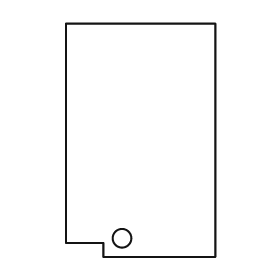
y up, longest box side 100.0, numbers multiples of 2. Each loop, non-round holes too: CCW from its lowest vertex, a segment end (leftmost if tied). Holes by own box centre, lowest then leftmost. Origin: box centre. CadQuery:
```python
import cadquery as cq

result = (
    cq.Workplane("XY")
    .moveTo(-16.0, -50.0)
    .lineTo(32.0, -50.0)
    .lineTo(32.0, 50.0)
    .lineTo(-32.0, 50.0)
    .lineTo(-32.0, -44.0)
    .lineTo(-16.0, -44.0)
    .close()
    .moveTo(-8.0, -42.0)
    .circle(4.0)
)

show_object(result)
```